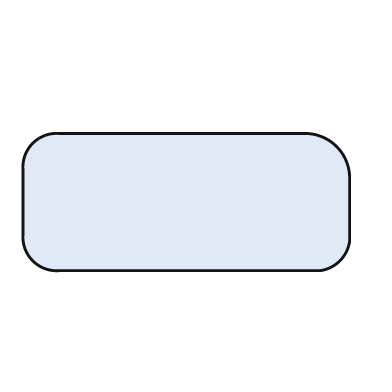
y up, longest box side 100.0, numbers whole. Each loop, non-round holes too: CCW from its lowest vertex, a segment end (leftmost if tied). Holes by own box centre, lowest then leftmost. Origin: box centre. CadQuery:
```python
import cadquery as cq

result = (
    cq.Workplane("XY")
    .moveTo(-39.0, -21.0)
    .lineTo(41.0, -21.0)
    .threePointArc((47.0, -18.0), (50.0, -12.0))
    .lineTo(50.0, 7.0)
    .threePointArc((46.0, 17.0), (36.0, 21.0))
    .lineTo(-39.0, 21.0)
    .threePointArc((-47.0, 18.0), (-50.0, 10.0))
    .lineTo(-50.0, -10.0)
    .threePointArc((-47.0, -18.0), (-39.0, -21.0))
    .close()
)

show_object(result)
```